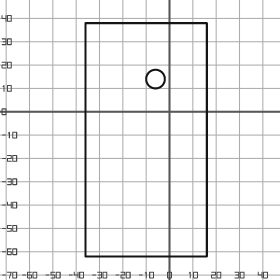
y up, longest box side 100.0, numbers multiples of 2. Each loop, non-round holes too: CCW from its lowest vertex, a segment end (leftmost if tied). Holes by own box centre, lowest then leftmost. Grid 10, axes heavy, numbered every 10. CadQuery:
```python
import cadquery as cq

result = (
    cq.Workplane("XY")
    .moveTo(-36.0, -62.0)
    .lineTo(16.0, -62.0)
    .lineTo(16.0, 38.0)
    .lineTo(-36.0, 38.0)
    .close()
    .moveTo(-6.0, 14.0)
    .circle(4.0)
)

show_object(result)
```